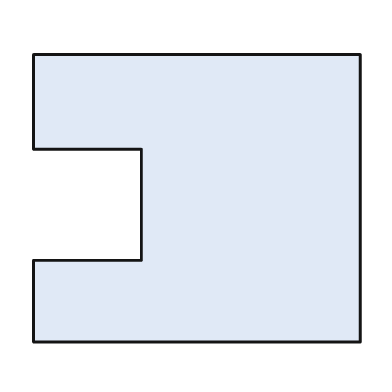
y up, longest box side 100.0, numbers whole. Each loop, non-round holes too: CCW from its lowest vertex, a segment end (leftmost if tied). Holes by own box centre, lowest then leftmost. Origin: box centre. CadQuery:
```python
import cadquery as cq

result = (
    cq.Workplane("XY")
    .moveTo(-50.0, -44.0)
    .lineTo(50.0, -44.0)
    .lineTo(50.0, 44.0)
    .lineTo(-50.0, 44.0)
    .lineTo(-50.0, 15.0)
    .lineTo(-17.0, 15.0)
    .lineTo(-17.0, -19.0)
    .lineTo(-50.0, -19.0)
    .close()
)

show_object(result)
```